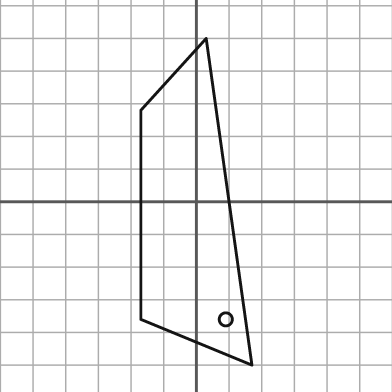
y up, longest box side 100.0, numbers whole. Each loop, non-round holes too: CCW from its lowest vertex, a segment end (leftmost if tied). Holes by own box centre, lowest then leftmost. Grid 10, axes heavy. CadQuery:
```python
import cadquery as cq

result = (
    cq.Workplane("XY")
    .moveTo(17.0, -50.0)
    .lineTo(3.0, 50.0)
    .lineTo(-17.0, 28.0)
    .lineTo(-17.0, -36.0)
    .close()
    .moveTo(9.0, -36.0)
    .circle(2.0)
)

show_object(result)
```